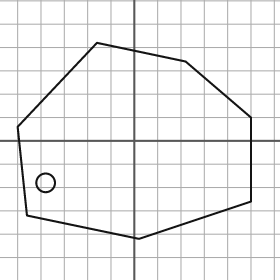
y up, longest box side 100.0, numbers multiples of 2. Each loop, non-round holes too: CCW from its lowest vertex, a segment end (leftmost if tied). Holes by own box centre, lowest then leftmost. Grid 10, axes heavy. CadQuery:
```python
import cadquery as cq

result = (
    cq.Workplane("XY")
    .moveTo(2.0, -42.0)
    .lineTo(50.0, -26.0)
    .lineTo(50.0, 10.0)
    .lineTo(22.0, 34.0)
    .lineTo(-16.0, 42.0)
    .lineTo(-50.0, 6.0)
    .lineTo(-46.0, -32.0)
    .close()
    .moveTo(-38.0, -18.0)
    .circle(4.0)
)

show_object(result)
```